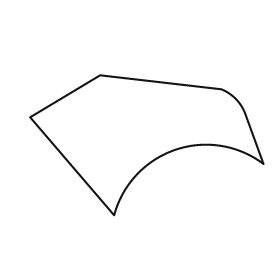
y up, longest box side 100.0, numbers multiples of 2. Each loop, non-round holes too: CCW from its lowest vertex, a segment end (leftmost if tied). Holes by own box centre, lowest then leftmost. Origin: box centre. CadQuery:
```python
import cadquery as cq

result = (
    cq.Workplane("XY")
    .moveTo(-14.0, -30.0)
    .threePointArc((12.0, -2.0), (50.0, -8.0))
    .lineTo(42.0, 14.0)
    .threePointArc((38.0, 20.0), (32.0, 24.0))
    .lineTo(-20.0, 30.0)
    .lineTo(-50.0, 12.0)
    .close()
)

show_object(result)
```